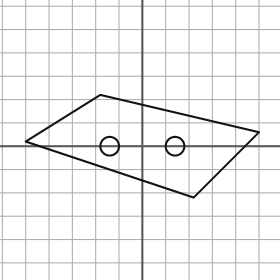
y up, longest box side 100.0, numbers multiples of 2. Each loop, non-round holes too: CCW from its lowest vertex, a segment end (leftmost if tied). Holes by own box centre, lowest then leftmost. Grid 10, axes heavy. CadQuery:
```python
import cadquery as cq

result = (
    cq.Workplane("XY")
    .moveTo(22.0, -22.0)
    .lineTo(50.0, 6.0)
    .lineTo(-18.0, 22.0)
    .lineTo(-50.0, 2.0)
    .close()
    .moveTo(-14.0, 0.0)
    .circle(4.0)
    .moveTo(14.0, 0.0)
    .circle(4.0)
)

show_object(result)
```